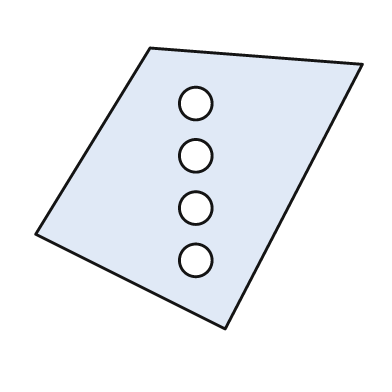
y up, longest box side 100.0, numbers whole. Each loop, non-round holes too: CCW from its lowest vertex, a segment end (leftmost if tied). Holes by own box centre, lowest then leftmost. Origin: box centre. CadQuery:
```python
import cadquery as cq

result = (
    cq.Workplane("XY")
    .moveTo(8.0, -43.0)
    .lineTo(50.0, 38.0)
    .lineTo(-15.0, 43.0)
    .lineTo(-50.0, -14.0)
    .close()
    .moveTo(-1.0, -22.0)
    .circle(5.0)
    .moveTo(-1.0, -6.0)
    .circle(5.0)
    .moveTo(-1.0, 10.0)
    .circle(5.0)
    .moveTo(-1.0, 26.0)
    .circle(5.0)
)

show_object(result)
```